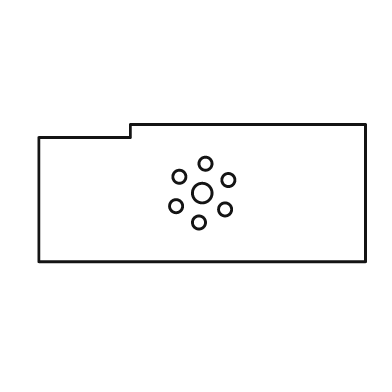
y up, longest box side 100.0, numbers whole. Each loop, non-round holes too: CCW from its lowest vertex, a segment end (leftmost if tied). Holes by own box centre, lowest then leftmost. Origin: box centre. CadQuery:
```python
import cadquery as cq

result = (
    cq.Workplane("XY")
    .moveTo(-50.0, -21.0)
    .lineTo(50.0, -21.0)
    .lineTo(50.0, 21.0)
    .lineTo(-22.0, 21.0)
    .lineTo(-22.0, 17.0)
    .lineTo(-50.0, 17.0)
    .close()
    .moveTo(-1.0, -9.0)
    .circle(2.0)
    .moveTo(7.0, -5.0)
    .circle(2.0)
    .moveTo(-8.0, -4.0)
    .circle(2.0)
    .moveTo(0.0, 0.0)
    .circle(3.0)
    .moveTo(8.0, 4.0)
    .circle(2.0)
    .moveTo(-7.0, 5.0)
    .circle(2.0)
    .moveTo(1.0, 9.0)
    .circle(2.0)
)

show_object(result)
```